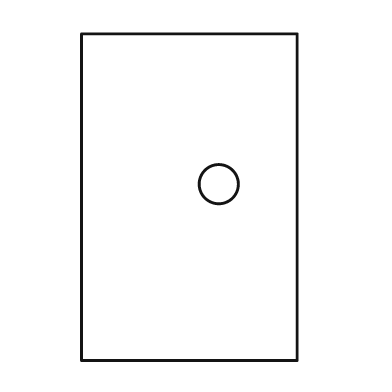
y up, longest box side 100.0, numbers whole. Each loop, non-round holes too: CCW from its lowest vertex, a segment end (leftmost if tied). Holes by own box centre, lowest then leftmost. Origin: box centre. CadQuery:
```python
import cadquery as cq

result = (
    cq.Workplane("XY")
    .moveTo(-33.0, -50.0)
    .lineTo(33.0, -50.0)
    .lineTo(33.0, 50.0)
    .lineTo(-33.0, 50.0)
    .close()
    .moveTo(9.0, 4.0)
    .circle(6.0)
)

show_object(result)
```